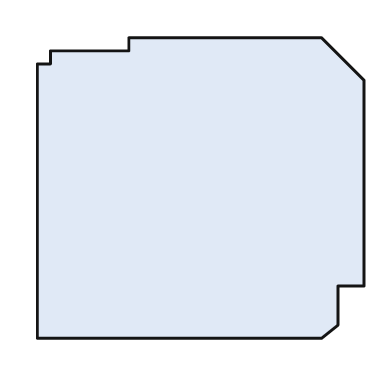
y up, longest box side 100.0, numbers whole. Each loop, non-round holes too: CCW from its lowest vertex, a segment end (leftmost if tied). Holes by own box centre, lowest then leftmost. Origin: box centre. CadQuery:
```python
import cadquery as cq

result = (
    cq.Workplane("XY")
    .moveTo(-50.0, -46.0)
    .lineTo(37.0, -46.0)
    .lineTo(42.0, -42.0)
    .lineTo(42.0, -30.0)
    .lineTo(50.0, -30.0)
    .lineTo(50.0, 33.0)
    .lineTo(37.0, 46.0)
    .lineTo(-22.0, 46.0)
    .lineTo(-22.0, 42.0)
    .lineTo(-46.0, 42.0)
    .lineTo(-46.0, 38.0)
    .lineTo(-50.0, 38.0)
    .close()
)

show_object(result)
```